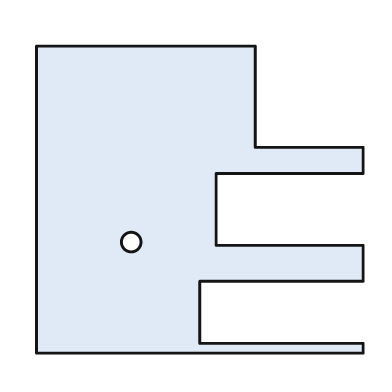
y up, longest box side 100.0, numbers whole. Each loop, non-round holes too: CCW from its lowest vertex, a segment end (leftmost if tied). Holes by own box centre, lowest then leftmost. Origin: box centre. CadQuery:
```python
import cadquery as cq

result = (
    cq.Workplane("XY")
    .moveTo(-50.0, -47.0)
    .lineTo(50.0, -47.0)
    .lineTo(50.0, -44.0)
    .lineTo(0.0, -44.0)
    .lineTo(0.0, -25.0)
    .lineTo(50.0, -25.0)
    .lineTo(50.0, -14.0)
    .lineTo(5.0, -14.0)
    .lineTo(5.0, 8.0)
    .lineTo(50.0, 8.0)
    .lineTo(50.0, 16.0)
    .lineTo(17.0, 16.0)
    .lineTo(17.0, 47.0)
    .lineTo(-50.0, 47.0)
    .close()
    .moveTo(-21.0, -13.0)
    .circle(3.0)
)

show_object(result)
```